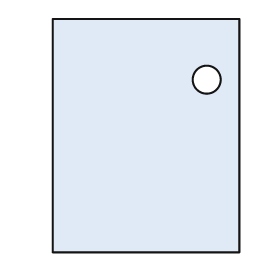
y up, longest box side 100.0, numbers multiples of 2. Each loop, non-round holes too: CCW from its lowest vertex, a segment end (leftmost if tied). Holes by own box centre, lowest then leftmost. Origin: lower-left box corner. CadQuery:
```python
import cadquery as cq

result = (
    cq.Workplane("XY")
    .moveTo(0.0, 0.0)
    .lineTo(80.0, 0.0)
    .lineTo(80.0, 100.0)
    .lineTo(0.0, 100.0)
    .close()
    .moveTo(66.0, 74.0)
    .circle(6.0)
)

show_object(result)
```